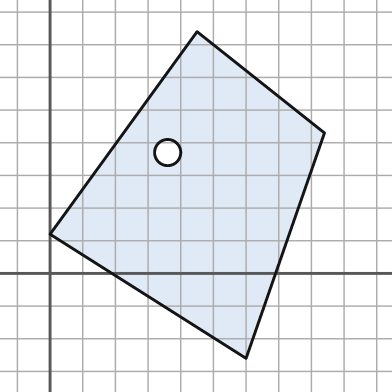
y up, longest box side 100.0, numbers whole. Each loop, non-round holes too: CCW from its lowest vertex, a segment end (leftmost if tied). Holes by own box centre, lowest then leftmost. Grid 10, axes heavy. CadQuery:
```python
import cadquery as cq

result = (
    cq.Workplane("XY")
    .moveTo(60.0, -26.0)
    .lineTo(84.0, 43.0)
    .lineTo(45.0, 74.0)
    .lineTo(0.0, 12.0)
    .close()
    .moveTo(36.0, 37.0)
    .circle(4.0)
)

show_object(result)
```